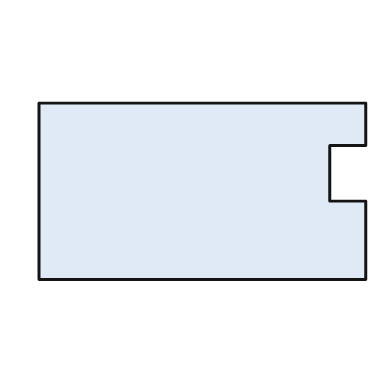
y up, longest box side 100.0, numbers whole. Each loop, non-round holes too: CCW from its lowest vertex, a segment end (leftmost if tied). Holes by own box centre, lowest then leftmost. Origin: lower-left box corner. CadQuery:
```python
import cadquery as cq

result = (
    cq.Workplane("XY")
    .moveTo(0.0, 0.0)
    .lineTo(100.0, 0.0)
    .lineTo(100.0, 24.0)
    .lineTo(89.0, 24.0)
    .lineTo(89.0, 41.0)
    .lineTo(100.0, 41.0)
    .lineTo(100.0, 54.0)
    .lineTo(0.0, 54.0)
    .close()
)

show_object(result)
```